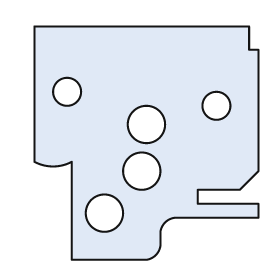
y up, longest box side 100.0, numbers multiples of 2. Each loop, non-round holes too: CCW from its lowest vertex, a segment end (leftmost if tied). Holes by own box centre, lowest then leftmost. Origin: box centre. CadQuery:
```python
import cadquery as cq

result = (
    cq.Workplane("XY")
    .moveTo(-32.0, -50.0)
    .lineTo(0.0, -50.0)
    .threePointArc((4.0, -48.0), (6.0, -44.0))
    .lineTo(6.0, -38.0)
    .threePointArc((8.0, -34.0), (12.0, -32.0))
    .lineTo(48.0, -32.0)
    .lineTo(48.0, -26.0)
    .lineTo(22.0, -26.0)
    .lineTo(22.0, -20.0)
    .lineTo(40.0, -20.0)
    .lineTo(48.0, -12.0)
    .lineTo(48.0, 40.0)
    .lineTo(44.0, 40.0)
    .lineTo(44.0, 50.0)
    .lineTo(-48.0, 50.0)
    .lineTo(-48.0, -8.0)
    .threePointArc((-40.0, -10.0), (-32.0, -8.0))
    .close()
    .moveTo(-18.0, -30.0)
    .circle(8.0)
    .moveTo(-2.0, -12.0)
    .circle(8.0)
    .moveTo(0.0, 8.0)
    .circle(8.0)
    .moveTo(30.0, 16.0)
    .circle(6.0)
    .moveTo(-34.0, 22.0)
    .circle(6.0)
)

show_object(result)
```